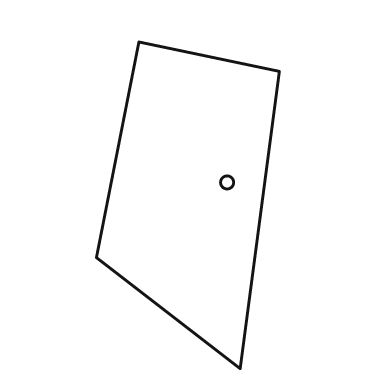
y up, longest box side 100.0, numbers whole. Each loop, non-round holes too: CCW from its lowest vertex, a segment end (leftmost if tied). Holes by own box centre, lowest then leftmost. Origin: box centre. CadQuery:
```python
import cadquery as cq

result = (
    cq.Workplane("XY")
    .moveTo(16.0, -50.0)
    .lineTo(28.0, 41.0)
    .lineTo(-15.0, 50.0)
    .lineTo(-28.0, -16.0)
    .close()
    .moveTo(12.0, 7.0)
    .circle(2.0)
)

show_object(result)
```